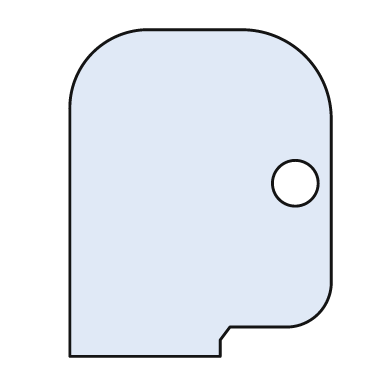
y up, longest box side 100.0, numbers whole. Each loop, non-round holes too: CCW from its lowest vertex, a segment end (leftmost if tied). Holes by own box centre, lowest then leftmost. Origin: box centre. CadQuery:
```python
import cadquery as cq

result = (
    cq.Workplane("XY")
    .moveTo(-40.0, -50.0)
    .lineTo(6.0, -50.0)
    .lineTo(6.0, -45.0)
    .lineTo(9.0, -41.0)
    .lineTo(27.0, -41.0)
    .threePointArc((36.0, -37.0), (40.0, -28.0))
    .lineTo(40.0, 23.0)
    .threePointArc((32.0, 42.0), (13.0, 50.0))
    .lineTo(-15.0, 50.0)
    .threePointArc((-33.0, 43.0), (-40.0, 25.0))
    .close()
    .moveTo(29.0, 3.0)
    .circle(7.0)
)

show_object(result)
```